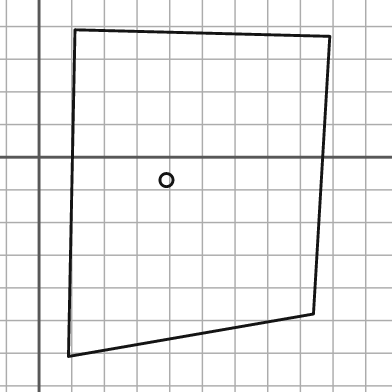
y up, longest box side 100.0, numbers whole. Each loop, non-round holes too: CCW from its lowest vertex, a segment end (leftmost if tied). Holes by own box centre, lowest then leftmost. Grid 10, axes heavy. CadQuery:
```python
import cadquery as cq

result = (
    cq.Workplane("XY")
    .moveTo(9.0, -61.0)
    .lineTo(84.0, -48.0)
    .lineTo(89.0, 37.0)
    .lineTo(11.0, 39.0)
    .close()
    .moveTo(39.0, -7.0)
    .circle(2.0)
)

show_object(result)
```